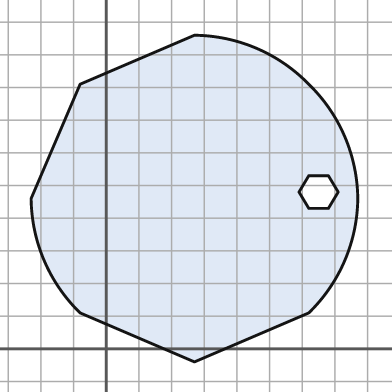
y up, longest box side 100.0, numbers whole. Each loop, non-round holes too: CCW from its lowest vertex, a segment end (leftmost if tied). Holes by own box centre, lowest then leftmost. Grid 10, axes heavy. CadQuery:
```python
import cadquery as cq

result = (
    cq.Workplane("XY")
    .moveTo(27.0, -4.0)
    .lineTo(62.0, 11.0)
    .threePointArc((73.0, 27.0), (77.0, 46.0))
    .threePointArc((73.0, 65.0), (62.0, 81.0))
    .threePointArc((46.0, 92.0), (27.0, 96.0))
    .lineTo(-8.0, 81.0)
    .lineTo(-23.0, 46.0)
    .threePointArc((-19.0, 27.0), (-8.0, 11.0))
    .close()
    .moveTo(62.0, 43.0)
    .lineTo(68.0, 43.0)
    .lineTo(71.0, 48.0)
    .lineTo(68.0, 53.0)
    .lineTo(62.0, 53.0)
    .lineTo(59.0, 48.0)
    .close()
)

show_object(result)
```